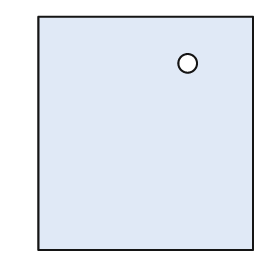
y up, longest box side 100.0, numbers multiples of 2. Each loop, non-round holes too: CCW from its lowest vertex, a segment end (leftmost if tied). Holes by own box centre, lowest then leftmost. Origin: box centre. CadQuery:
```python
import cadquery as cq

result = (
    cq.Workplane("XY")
    .moveTo(-46.0, -50.0)
    .lineTo(46.0, -50.0)
    .lineTo(46.0, 50.0)
    .lineTo(-46.0, 50.0)
    .close()
    .moveTo(18.0, 30.0)
    .circle(4.0)
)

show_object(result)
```